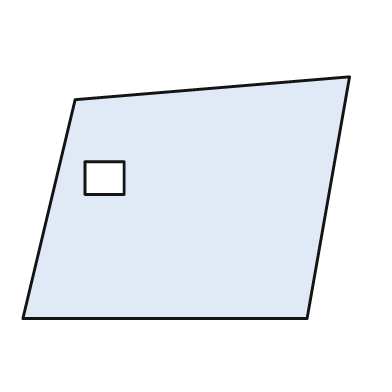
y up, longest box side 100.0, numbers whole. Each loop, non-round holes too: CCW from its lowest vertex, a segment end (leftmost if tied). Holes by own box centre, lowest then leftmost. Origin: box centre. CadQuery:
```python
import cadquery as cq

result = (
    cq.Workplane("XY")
    .moveTo(-50.0, -37.0)
    .lineTo(37.0, -37.0)
    .lineTo(50.0, 37.0)
    .lineTo(-34.0, 30.0)
    .close()
    .moveTo(-31.0, 1.0)
    .lineTo(-19.0, 1.0)
    .lineTo(-19.0, 11.0)
    .lineTo(-31.0, 11.0)
    .close()
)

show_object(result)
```